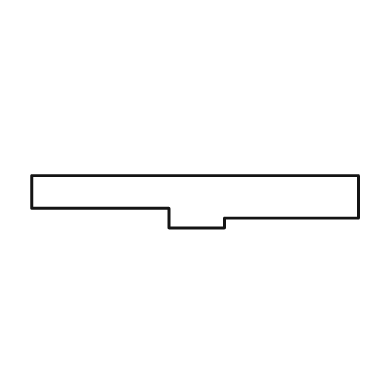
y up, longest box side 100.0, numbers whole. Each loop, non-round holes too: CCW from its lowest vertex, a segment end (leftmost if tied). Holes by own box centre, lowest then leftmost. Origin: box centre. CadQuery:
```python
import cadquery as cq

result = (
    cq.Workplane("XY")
    .moveTo(-8.0, -8.0)
    .lineTo(9.0, -8.0)
    .lineTo(9.0, -5.0)
    .lineTo(50.0, -5.0)
    .lineTo(50.0, 8.0)
    .lineTo(-50.0, 8.0)
    .lineTo(-50.0, -2.0)
    .lineTo(-8.0, -2.0)
    .close()
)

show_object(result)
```